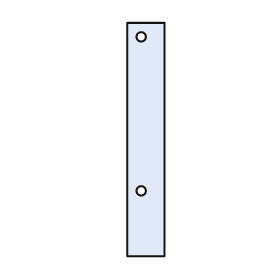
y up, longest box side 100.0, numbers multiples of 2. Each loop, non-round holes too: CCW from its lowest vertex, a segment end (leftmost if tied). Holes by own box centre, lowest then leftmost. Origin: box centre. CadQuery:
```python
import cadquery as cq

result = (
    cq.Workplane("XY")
    .moveTo(-8.0, -50.0)
    .lineTo(8.0, -50.0)
    .lineTo(8.0, 50.0)
    .lineTo(-8.0, 50.0)
    .close()
    .moveTo(-2.0, -22.0)
    .circle(2.0)
    .moveTo(-2.0, 44.0)
    .circle(2.0)
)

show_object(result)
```